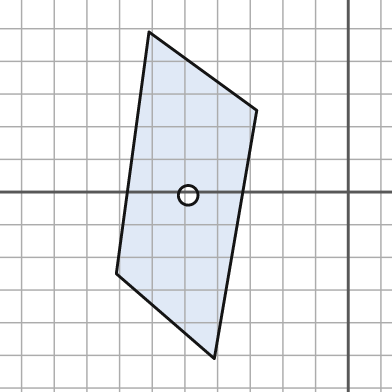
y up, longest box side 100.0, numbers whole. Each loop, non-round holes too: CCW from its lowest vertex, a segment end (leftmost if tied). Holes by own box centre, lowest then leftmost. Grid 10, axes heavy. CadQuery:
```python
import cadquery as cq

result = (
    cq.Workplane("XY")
    .moveTo(-41.0, -51.0)
    .lineTo(-28.0, 25.0)
    .lineTo(-61.0, 49.0)
    .lineTo(-71.0, -25.0)
    .close()
    .moveTo(-49.0, -1.0)
    .circle(3.0)
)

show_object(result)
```